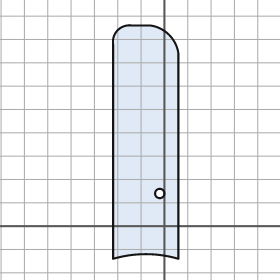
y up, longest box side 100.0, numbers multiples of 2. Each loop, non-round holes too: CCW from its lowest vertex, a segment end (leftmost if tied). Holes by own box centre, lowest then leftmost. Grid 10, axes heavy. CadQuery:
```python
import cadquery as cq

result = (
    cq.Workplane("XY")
    .moveTo(-22.0, -14.0)
    .threePointArc((-8.0, -12.0), (6.0, -14.0))
    .lineTo(6.0, 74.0)
    .threePointArc((2.0, 82.0), (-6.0, 86.0))
    .lineTo(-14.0, 86.0)
    .threePointArc((-20.0, 84.0), (-22.0, 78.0))
    .close()
    .moveTo(-2.0, 14.0)
    .circle(2.0)
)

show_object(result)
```